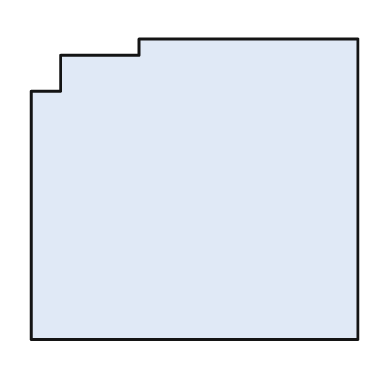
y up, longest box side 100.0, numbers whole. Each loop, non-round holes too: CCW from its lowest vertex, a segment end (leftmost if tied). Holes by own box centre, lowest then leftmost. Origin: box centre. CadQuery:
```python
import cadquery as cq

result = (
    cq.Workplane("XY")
    .moveTo(-50.0, -46.0)
    .lineTo(50.0, -46.0)
    .lineTo(50.0, 46.0)
    .lineTo(-17.0, 46.0)
    .lineTo(-17.0, 41.0)
    .lineTo(-41.0, 41.0)
    .lineTo(-41.0, 30.0)
    .lineTo(-50.0, 30.0)
    .close()
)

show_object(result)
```